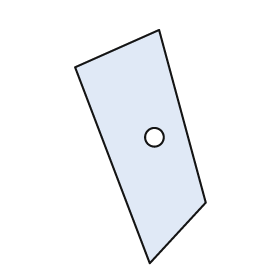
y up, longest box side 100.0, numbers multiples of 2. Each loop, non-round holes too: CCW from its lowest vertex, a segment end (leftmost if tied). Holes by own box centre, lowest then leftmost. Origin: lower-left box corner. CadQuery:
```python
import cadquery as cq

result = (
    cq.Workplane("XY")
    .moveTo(32.0, 0.0)
    .lineTo(56.0, 26.0)
    .lineTo(36.0, 100.0)
    .lineTo(0.0, 84.0)
    .close()
    .moveTo(34.0, 54.0)
    .circle(4.0)
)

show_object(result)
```